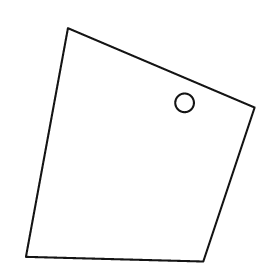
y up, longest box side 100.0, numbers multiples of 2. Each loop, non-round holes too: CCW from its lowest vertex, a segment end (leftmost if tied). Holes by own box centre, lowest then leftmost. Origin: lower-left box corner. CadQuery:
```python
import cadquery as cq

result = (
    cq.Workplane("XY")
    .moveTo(76.0, 0.0)
    .lineTo(98.0, 66.0)
    .lineTo(18.0, 100.0)
    .lineTo(0.0, 2.0)
    .close()
    .moveTo(68.0, 68.0)
    .circle(4.0)
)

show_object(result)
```